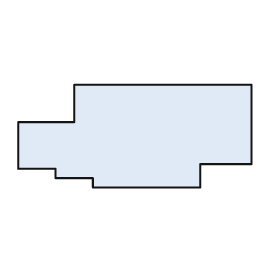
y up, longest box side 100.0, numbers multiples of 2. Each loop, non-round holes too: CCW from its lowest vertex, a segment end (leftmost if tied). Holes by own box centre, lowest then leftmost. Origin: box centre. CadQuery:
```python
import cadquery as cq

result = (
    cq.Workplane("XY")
    .moveTo(-18.0, -22.0)
    .lineTo(28.0, -22.0)
    .lineTo(28.0, -12.0)
    .lineTo(50.0, -12.0)
    .lineTo(50.0, 22.0)
    .lineTo(-26.0, 22.0)
    .lineTo(-26.0, 6.0)
    .lineTo(-50.0, 6.0)
    .lineTo(-50.0, -14.0)
    .lineTo(-34.0, -14.0)
    .lineTo(-34.0, -18.0)
    .lineTo(-18.0, -18.0)
    .close()
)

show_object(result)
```